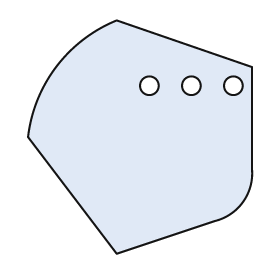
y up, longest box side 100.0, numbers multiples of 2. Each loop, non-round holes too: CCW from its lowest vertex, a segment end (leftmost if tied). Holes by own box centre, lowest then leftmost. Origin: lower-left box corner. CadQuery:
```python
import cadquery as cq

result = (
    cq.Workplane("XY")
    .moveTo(38.0, 0.0)
    .lineTo(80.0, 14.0)
    .threePointArc((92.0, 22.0), (96.0, 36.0))
    .lineTo(96.0, 80.0)
    .lineTo(38.0, 100.0)
    .threePointArc((12.0, 80.0), (0.0, 50.0))
    .close()
    .moveTo(52.0, 72.0)
    .circle(4.0)
    .moveTo(70.0, 72.0)
    .circle(4.0)
    .moveTo(88.0, 72.0)
    .circle(4.0)
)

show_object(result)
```